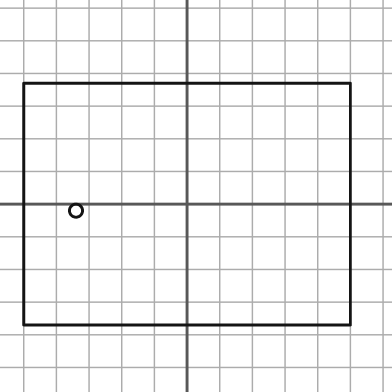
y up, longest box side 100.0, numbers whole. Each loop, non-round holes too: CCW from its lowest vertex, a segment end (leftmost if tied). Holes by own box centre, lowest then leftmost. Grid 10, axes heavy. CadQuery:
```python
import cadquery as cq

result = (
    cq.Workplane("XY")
    .moveTo(-50.0, -37.0)
    .lineTo(50.0, -37.0)
    .lineTo(50.0, 37.0)
    .lineTo(-50.0, 37.0)
    .close()
    .moveTo(-34.0, -2.0)
    .circle(2.0)
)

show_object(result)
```